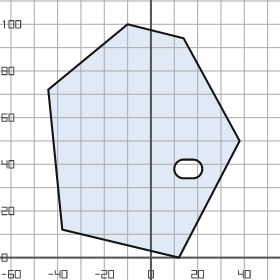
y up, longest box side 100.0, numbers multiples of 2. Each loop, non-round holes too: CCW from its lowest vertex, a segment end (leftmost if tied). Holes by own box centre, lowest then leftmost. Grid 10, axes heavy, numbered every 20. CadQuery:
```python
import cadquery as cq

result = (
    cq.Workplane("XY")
    .moveTo(12.0, 0.0)
    .lineTo(38.0, 50.0)
    .lineTo(14.0, 94.0)
    .lineTo(-10.0, 100.0)
    .lineTo(-44.0, 72.0)
    .lineTo(-38.0, 12.0)
    .close()
    .moveTo(14.0, 34.0)
    .lineTo(18.0, 34.0)
    .threePointArc((22.0, 38.0), (18.0, 42.0))
    .lineTo(14.0, 42.0)
    .threePointArc((10.0, 38.0), (14.0, 34.0))
    .close()
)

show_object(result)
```